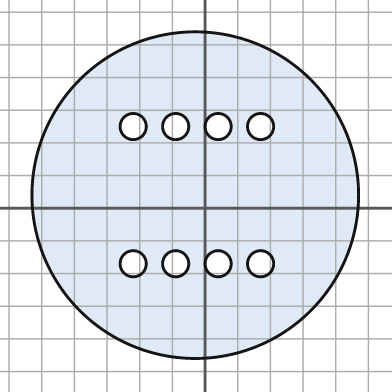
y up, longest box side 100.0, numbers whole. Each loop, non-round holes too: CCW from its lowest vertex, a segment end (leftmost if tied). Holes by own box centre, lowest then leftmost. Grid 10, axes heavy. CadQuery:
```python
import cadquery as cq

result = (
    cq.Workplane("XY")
    .moveTo(-3.0, 4.0)
    .circle(50.0)
    .moveTo(-22.0, -17.0)
    .circle(4.0)
    .moveTo(-9.0, -17.0)
    .circle(4.0)
    .moveTo(4.0, -17.0)
    .circle(4.0)
    .moveTo(17.0, -17.0)
    .circle(4.0)
    .moveTo(-22.0, 25.0)
    .circle(4.0)
    .moveTo(-9.0, 25.0)
    .circle(4.0)
    .moveTo(4.0, 25.0)
    .circle(4.0)
    .moveTo(17.0, 25.0)
    .circle(4.0)
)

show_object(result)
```